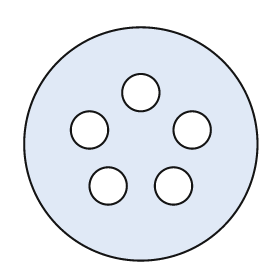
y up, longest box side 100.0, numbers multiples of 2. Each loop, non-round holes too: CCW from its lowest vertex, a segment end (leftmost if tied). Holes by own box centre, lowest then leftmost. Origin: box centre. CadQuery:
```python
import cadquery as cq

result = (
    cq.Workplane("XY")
    .moveTo(0.0, 0.0)
    .circle(50.0)
    .moveTo(-14.0, -18.0)
    .circle(8.0)
    .moveTo(14.0, -18.0)
    .circle(8.0)
    .moveTo(-22.0, 6.0)
    .circle(8.0)
    .moveTo(22.0, 6.0)
    .circle(8.0)
    .moveTo(0.0, 22.0)
    .circle(8.0)
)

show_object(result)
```